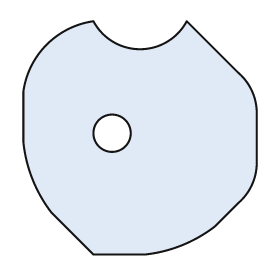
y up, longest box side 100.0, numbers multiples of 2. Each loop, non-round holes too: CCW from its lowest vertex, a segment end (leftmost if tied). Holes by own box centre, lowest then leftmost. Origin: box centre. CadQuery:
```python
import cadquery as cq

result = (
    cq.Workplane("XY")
    .moveTo(-20.0, -50.0)
    .lineTo(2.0, -50.0)
    .threePointArc((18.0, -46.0), (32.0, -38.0))
    .lineTo(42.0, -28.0)
    .threePointArc((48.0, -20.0), (50.0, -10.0))
    .lineTo(50.0, 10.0)
    .threePointArc((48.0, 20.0), (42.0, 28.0))
    .lineTo(20.0, 50.0)
    .threePointArc((0.0, 38.0), (-20.0, 50.0))
    .threePointArc((-40.0, 40.0), (-50.0, 20.0))
    .lineTo(-50.0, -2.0)
    .threePointArc((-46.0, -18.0), (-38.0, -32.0))
    .close()
    .moveTo(-12.0, 2.0)
    .circle(8.0)
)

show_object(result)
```